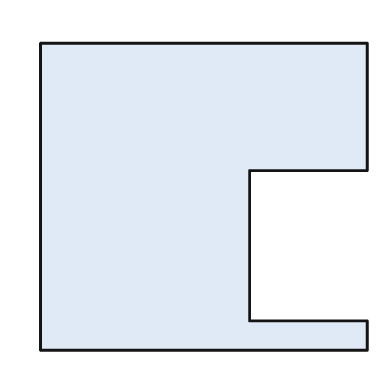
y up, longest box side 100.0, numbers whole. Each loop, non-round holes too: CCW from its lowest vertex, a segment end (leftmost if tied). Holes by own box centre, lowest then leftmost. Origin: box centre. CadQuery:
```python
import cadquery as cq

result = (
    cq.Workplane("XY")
    .moveTo(-50.0, -47.0)
    .lineTo(50.0, -47.0)
    .lineTo(50.0, -38.0)
    .lineTo(14.0, -38.0)
    .lineTo(14.0, 8.0)
    .lineTo(50.0, 8.0)
    .lineTo(50.0, 47.0)
    .lineTo(-50.0, 47.0)
    .close()
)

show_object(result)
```